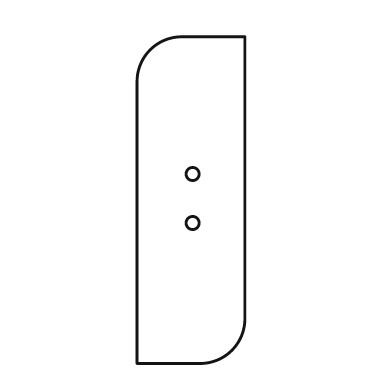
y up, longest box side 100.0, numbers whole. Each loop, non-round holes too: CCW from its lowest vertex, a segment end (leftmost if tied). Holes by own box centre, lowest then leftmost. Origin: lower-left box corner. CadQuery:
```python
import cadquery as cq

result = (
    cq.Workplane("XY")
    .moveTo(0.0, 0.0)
    .lineTo(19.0, 0.0)
    .threePointArc((29.0, 4.0), (33.0, 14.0))
    .lineTo(33.0, 100.0)
    .lineTo(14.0, 100.0)
    .threePointArc((4.0, 96.0), (0.0, 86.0))
    .close()
    .moveTo(17.0, 43.0)
    .circle(2.0)
    .moveTo(17.0, 58.0)
    .circle(2.0)
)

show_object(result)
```